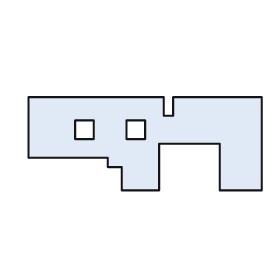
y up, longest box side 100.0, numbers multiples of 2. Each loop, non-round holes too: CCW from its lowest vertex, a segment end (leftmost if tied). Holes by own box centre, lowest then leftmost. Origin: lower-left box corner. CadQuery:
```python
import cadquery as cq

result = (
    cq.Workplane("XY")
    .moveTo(40.0, 0.0)
    .lineTo(56.0, 0.0)
    .lineTo(56.0, 20.0)
    .lineTo(82.0, 20.0)
    .lineTo(82.0, 0.0)
    .lineTo(100.0, 0.0)
    .lineTo(100.0, 40.0)
    .lineTo(62.0, 40.0)
    .lineTo(62.0, 32.0)
    .lineTo(58.0, 32.0)
    .lineTo(58.0, 40.0)
    .lineTo(0.0, 40.0)
    .lineTo(0.0, 14.0)
    .lineTo(34.0, 14.0)
    .lineTo(34.0, 10.0)
    .lineTo(40.0, 10.0)
    .close()
    .moveTo(20.0, 22.0)
    .lineTo(28.0, 22.0)
    .lineTo(28.0, 30.0)
    .lineTo(20.0, 30.0)
    .close()
    .moveTo(42.0, 22.0)
    .lineTo(50.0, 22.0)
    .lineTo(50.0, 30.0)
    .lineTo(42.0, 30.0)
    .close()
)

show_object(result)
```